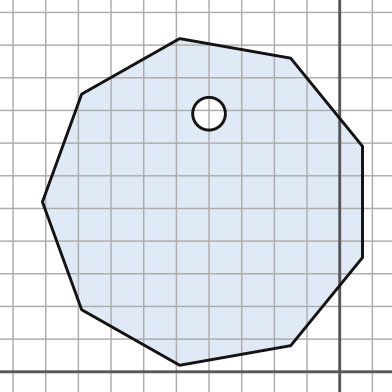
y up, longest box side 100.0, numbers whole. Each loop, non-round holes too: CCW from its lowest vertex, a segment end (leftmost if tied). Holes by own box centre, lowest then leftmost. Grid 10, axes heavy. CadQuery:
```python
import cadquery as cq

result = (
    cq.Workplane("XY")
    .moveTo(-49.0, 2.0)
    .lineTo(-15.0, 8.0)
    .lineTo(7.0, 35.0)
    .lineTo(7.0, 69.0)
    .lineTo(-15.0, 96.0)
    .lineTo(-49.0, 102.0)
    .lineTo(-79.0, 85.0)
    .lineTo(-91.0, 52.0)
    .lineTo(-79.0, 19.0)
    .close()
    .moveTo(-40.0, 79.0)
    .circle(5.0)
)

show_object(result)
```